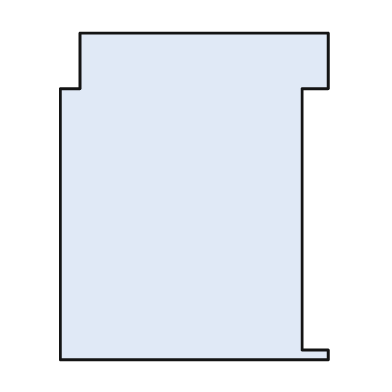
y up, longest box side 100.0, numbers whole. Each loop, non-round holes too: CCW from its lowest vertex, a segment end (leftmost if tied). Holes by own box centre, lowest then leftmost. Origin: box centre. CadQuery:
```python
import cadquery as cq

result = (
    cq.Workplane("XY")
    .moveTo(-41.0, -50.0)
    .lineTo(41.0, -50.0)
    .lineTo(41.0, -47.0)
    .lineTo(33.0, -47.0)
    .lineTo(33.0, 33.0)
    .lineTo(41.0, 33.0)
    .lineTo(41.0, 50.0)
    .lineTo(-35.0, 50.0)
    .lineTo(-35.0, 33.0)
    .lineTo(-41.0, 33.0)
    .close()
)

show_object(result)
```